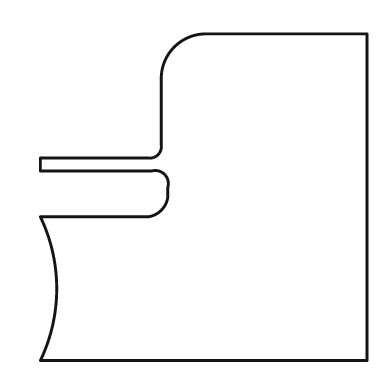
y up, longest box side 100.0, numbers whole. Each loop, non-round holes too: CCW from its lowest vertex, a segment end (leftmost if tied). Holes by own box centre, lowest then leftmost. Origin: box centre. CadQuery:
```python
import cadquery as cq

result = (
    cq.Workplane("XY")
    .moveTo(-50.0, -50.0)
    .lineTo(50.0, -50.0)
    .lineTo(50.0, 50.0)
    .lineTo(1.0, 50.0)
    .threePointArc((-9.0, 46.0), (-13.0, 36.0))
    .lineTo(-13.0, 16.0)
    .threePointArc((-14.0, 13.0), (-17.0, 12.0))
    .lineTo(-50.0, 12.0)
    .lineTo(-50.0, 8.0)
    .lineTo(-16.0, 8.0)
    .threePointArc((-12.0, 7.0), (-11.0, 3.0))
    .lineTo(-11.0, 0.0)
    .threePointArc((-13.0, -4.0), (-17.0, -6.0))
    .lineTo(-50.0, -6.0)
    .threePointArc((-45.0, -28.0), (-50.0, -50.0))
    .close()
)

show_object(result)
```